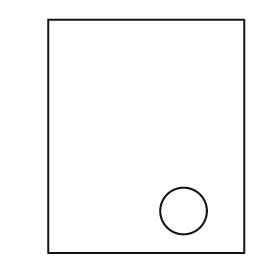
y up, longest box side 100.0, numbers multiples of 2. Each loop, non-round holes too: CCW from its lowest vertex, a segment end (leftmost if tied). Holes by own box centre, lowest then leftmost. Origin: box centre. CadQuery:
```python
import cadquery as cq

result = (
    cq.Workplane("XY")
    .moveTo(-42.0, -50.0)
    .lineTo(42.0, -50.0)
    .lineTo(42.0, 50.0)
    .lineTo(-42.0, 50.0)
    .close()
    .moveTo(16.0, -32.0)
    .circle(10.0)
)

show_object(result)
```